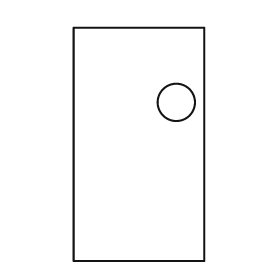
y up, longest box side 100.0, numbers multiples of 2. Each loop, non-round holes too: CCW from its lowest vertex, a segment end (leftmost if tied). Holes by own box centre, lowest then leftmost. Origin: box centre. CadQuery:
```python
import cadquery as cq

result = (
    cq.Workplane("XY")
    .moveTo(-28.0, -50.0)
    .lineTo(28.0, -50.0)
    .lineTo(28.0, 50.0)
    .lineTo(-28.0, 50.0)
    .close()
    .moveTo(16.0, 18.0)
    .circle(8.0)
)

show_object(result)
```